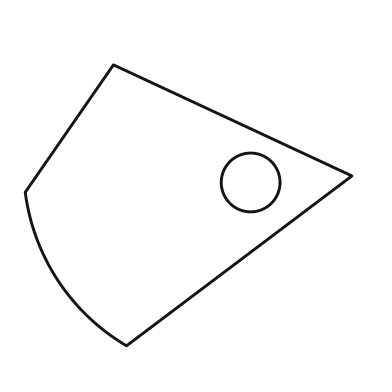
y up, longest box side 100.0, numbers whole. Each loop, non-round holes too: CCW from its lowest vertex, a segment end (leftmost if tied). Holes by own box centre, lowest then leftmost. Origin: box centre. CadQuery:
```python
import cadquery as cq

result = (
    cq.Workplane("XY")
    .moveTo(-19.0, -43.0)
    .lineTo(50.0, 9.0)
    .lineTo(-23.0, 43.0)
    .lineTo(-50.0, 4.0)
    .threePointArc((-40.0, -23.0), (-19.0, -43.0))
    .close()
    .moveTo(19.0, 7.0)
    .circle(9.0)
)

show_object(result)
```